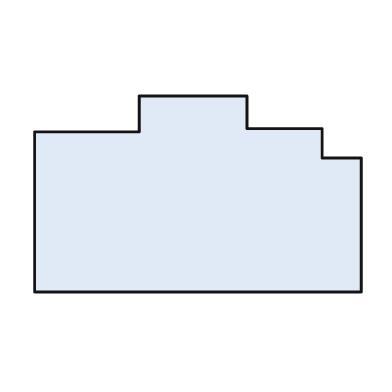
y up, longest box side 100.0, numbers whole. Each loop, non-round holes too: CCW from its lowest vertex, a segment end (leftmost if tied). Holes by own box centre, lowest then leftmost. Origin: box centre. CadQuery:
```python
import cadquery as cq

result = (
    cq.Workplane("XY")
    .moveTo(-50.0, -30.0)
    .lineTo(50.0, -30.0)
    .lineTo(50.0, 11.0)
    .lineTo(38.0, 11.0)
    .lineTo(38.0, 20.0)
    .lineTo(15.0, 20.0)
    .lineTo(15.0, 30.0)
    .lineTo(-18.0, 30.0)
    .lineTo(-18.0, 19.0)
    .lineTo(-50.0, 19.0)
    .close()
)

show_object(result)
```